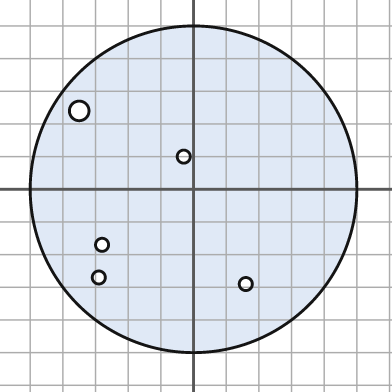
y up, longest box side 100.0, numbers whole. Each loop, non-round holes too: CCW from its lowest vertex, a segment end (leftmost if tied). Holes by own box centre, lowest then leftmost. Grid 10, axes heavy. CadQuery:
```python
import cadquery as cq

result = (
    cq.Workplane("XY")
    .moveTo(0.0, 0.0)
    .circle(50.0)
    .moveTo(16.0, -29.0)
    .circle(2.0)
    .moveTo(-29.0, -27.0)
    .circle(2.0)
    .moveTo(-28.0, -17.0)
    .circle(2.0)
    .moveTo(-3.0, 10.0)
    .circle(2.0)
    .moveTo(-35.0, 24.0)
    .circle(3.0)
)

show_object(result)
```